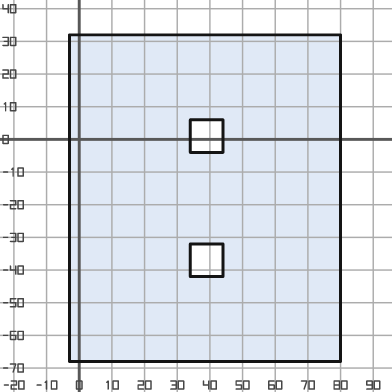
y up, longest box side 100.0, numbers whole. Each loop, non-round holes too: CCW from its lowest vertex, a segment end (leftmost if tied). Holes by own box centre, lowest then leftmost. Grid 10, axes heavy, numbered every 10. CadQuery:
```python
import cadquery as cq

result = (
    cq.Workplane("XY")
    .moveTo(-3.0, -68.0)
    .lineTo(80.0, -68.0)
    .lineTo(80.0, 32.0)
    .lineTo(-3.0, 32.0)
    .close()
    .moveTo(34.0, -42.0)
    .lineTo(44.0, -42.0)
    .lineTo(44.0, -32.0)
    .lineTo(34.0, -32.0)
    .close()
    .moveTo(34.0, -4.0)
    .lineTo(44.0, -4.0)
    .lineTo(44.0, 6.0)
    .lineTo(34.0, 6.0)
    .close()
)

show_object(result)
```